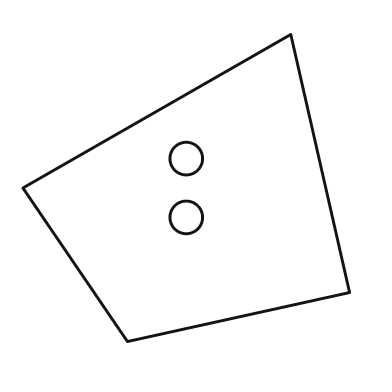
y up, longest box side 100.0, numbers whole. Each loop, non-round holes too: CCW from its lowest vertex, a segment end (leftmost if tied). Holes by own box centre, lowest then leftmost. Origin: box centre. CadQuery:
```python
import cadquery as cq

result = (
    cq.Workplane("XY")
    .moveTo(-18.0, -47.0)
    .lineTo(50.0, -32.0)
    .lineTo(32.0, 47.0)
    .lineTo(-50.0, 0.0)
    .close()
    .moveTo(0.0, -9.0)
    .circle(5.0)
    .moveTo(0.0, 9.0)
    .circle(5.0)
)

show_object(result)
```